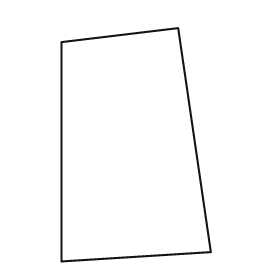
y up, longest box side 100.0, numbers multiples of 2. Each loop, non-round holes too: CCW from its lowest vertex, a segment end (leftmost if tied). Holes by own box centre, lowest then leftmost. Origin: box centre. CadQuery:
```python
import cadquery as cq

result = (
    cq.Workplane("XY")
    .moveTo(-32.0, -50.0)
    .lineTo(32.0, -46.0)
    .lineTo(18.0, 50.0)
    .lineTo(-32.0, 44.0)
    .close()
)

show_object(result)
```